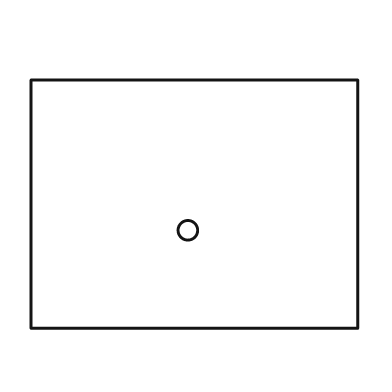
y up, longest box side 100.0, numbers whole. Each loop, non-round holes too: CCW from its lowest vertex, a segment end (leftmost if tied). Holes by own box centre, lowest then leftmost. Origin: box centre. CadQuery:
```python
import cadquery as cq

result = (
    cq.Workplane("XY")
    .moveTo(-50.0, -38.0)
    .lineTo(50.0, -38.0)
    .lineTo(50.0, 38.0)
    .lineTo(-50.0, 38.0)
    .close()
    .moveTo(-2.0, -8.0)
    .circle(3.0)
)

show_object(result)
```